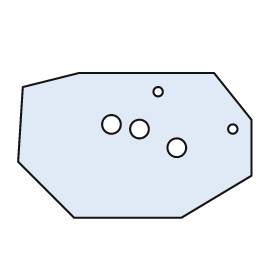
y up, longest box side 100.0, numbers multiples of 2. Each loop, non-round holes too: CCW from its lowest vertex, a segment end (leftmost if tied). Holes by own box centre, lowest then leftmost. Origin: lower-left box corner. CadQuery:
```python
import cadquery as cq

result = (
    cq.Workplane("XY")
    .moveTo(24.0, 0.0)
    .lineTo(70.0, 0.0)
    .lineTo(100.0, 18.0)
    .lineTo(100.0, 42.0)
    .lineTo(84.0, 62.0)
    .lineTo(26.0, 62.0)
    .lineTo(2.0, 56.0)
    .lineTo(0.0, 24.0)
    .close()
    .moveTo(68.0, 30.0)
    .circle(4.0)
    .moveTo(52.0, 38.0)
    .circle(4.0)
    .moveTo(92.0, 38.0)
    .circle(2.0)
    .moveTo(40.0, 40.0)
    .circle(4.0)
    .moveTo(60.0, 54.0)
    .circle(2.0)
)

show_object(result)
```